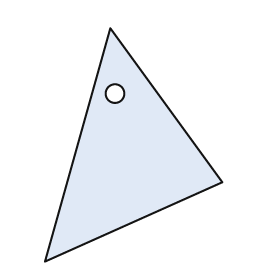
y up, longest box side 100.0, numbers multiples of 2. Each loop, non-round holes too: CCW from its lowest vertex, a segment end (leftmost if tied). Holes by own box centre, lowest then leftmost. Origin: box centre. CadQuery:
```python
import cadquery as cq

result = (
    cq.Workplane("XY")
    .moveTo(-38.0, -50.0)
    .lineTo(38.0, -16.0)
    .lineTo(-10.0, 50.0)
    .close()
    .moveTo(-8.0, 22.0)
    .circle(4.0)
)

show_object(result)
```